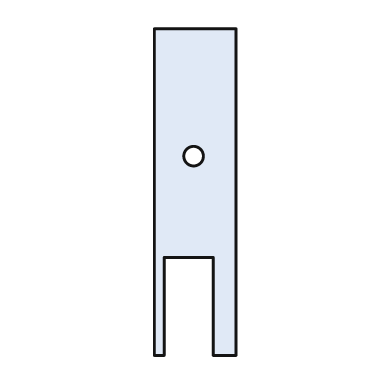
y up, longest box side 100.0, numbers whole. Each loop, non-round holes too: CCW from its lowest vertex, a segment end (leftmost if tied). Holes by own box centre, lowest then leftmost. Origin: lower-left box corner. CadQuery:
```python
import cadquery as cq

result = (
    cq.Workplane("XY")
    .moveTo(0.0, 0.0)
    .lineTo(3.0, 0.0)
    .lineTo(3.0, 30.0)
    .lineTo(18.0, 30.0)
    .lineTo(18.0, 0.0)
    .lineTo(25.0, 0.0)
    .lineTo(25.0, 100.0)
    .lineTo(0.0, 100.0)
    .close()
    .moveTo(12.0, 61.0)
    .circle(3.0)
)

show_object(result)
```